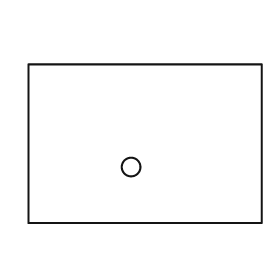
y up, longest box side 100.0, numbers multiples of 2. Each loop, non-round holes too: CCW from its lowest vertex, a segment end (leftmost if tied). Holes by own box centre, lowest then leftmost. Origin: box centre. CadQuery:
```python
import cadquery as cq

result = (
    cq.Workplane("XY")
    .moveTo(-50.0, -34.0)
    .lineTo(50.0, -34.0)
    .lineTo(50.0, 34.0)
    .lineTo(-50.0, 34.0)
    .close()
    .moveTo(-6.0, -10.0)
    .circle(4.0)
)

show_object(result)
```